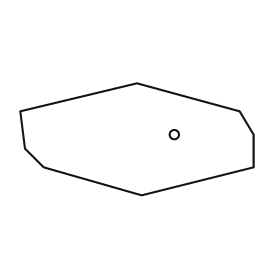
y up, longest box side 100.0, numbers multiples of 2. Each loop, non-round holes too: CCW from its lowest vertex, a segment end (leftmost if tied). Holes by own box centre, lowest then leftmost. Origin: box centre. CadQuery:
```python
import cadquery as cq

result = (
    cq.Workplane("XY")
    .moveTo(2.0, -24.0)
    .lineTo(50.0, -12.0)
    .lineTo(50.0, 2.0)
    .lineTo(44.0, 12.0)
    .lineTo(0.0, 24.0)
    .lineTo(-50.0, 12.0)
    .lineTo(-48.0, -4.0)
    .lineTo(-40.0, -12.0)
    .close()
    .moveTo(16.0, 2.0)
    .circle(2.0)
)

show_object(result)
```